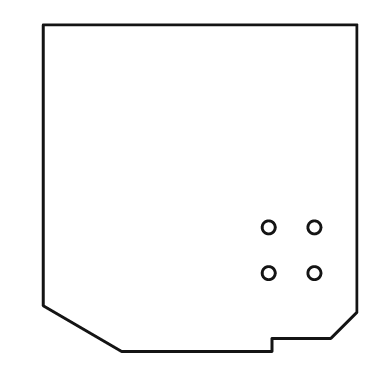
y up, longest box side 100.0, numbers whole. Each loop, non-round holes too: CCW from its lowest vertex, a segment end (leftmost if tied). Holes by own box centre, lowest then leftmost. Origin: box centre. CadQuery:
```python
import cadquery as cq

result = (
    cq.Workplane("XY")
    .moveTo(-24.0, -50.0)
    .lineTo(22.0, -50.0)
    .lineTo(22.0, -46.0)
    .lineTo(40.0, -46.0)
    .lineTo(48.0, -38.0)
    .lineTo(48.0, 50.0)
    .lineTo(-48.0, 50.0)
    .lineTo(-48.0, -36.0)
    .close()
    .moveTo(21.0, -26.0)
    .circle(2.0)
    .moveTo(35.0, -26.0)
    .circle(2.0)
    .moveTo(21.0, -12.0)
    .circle(2.0)
    .moveTo(35.0, -12.0)
    .circle(2.0)
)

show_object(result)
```